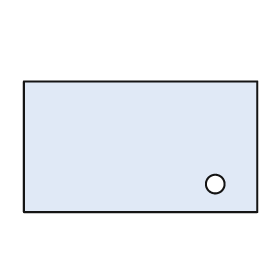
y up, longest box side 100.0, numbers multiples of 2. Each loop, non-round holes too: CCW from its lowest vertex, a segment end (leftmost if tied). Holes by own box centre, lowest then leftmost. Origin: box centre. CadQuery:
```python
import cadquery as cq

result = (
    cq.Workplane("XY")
    .moveTo(-50.0, -28.0)
    .lineTo(50.0, -28.0)
    .lineTo(50.0, 28.0)
    .lineTo(-50.0, 28.0)
    .close()
    .moveTo(32.0, -16.0)
    .circle(4.0)
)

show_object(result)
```